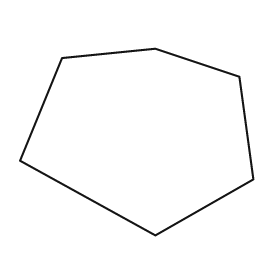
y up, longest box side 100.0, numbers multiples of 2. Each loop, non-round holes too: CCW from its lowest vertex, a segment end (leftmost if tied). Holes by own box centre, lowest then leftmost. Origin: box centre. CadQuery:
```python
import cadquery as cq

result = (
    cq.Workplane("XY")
    .moveTo(8.0, -40.0)
    .lineTo(50.0, -16.0)
    .lineTo(44.0, 28.0)
    .lineTo(8.0, 40.0)
    .lineTo(-32.0, 36.0)
    .lineTo(-50.0, -8.0)
    .close()
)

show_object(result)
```